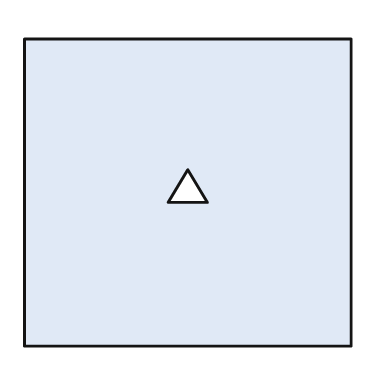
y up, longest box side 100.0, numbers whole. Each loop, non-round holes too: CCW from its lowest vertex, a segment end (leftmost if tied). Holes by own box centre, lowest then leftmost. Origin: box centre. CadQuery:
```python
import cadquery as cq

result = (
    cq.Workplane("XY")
    .moveTo(-50.0, -47.0)
    .lineTo(50.0, -47.0)
    .lineTo(50.0, 47.0)
    .lineTo(-50.0, 47.0)
    .close()
    .moveTo(-6.0, -3.0)
    .lineTo(6.0, -3.0)
    .lineTo(0.0, 7.0)
    .close()
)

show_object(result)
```